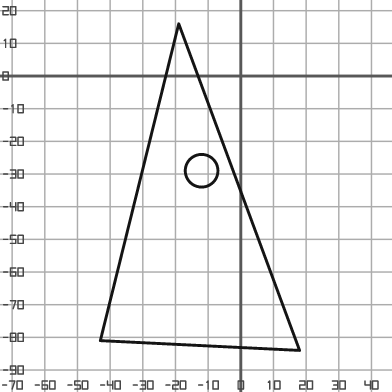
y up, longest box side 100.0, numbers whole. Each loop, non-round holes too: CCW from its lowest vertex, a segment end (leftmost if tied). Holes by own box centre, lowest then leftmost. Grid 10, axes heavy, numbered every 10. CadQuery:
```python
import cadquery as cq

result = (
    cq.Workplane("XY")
    .moveTo(18.0, -84.0)
    .lineTo(-19.0, 16.0)
    .lineTo(-43.0, -81.0)
    .close()
    .moveTo(-12.0, -29.0)
    .circle(5.0)
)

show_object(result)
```